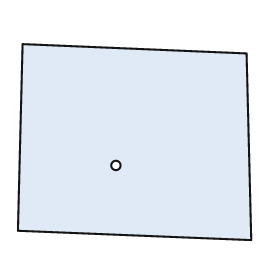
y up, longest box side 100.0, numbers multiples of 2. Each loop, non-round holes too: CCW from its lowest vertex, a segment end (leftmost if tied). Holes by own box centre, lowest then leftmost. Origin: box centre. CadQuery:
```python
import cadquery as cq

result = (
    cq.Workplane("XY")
    .moveTo(50.0, -42.0)
    .lineTo(48.0, 38.0)
    .lineTo(-48.0, 42.0)
    .lineTo(-50.0, -38.0)
    .close()
    .moveTo(-8.0, -10.0)
    .circle(2.0)
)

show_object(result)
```